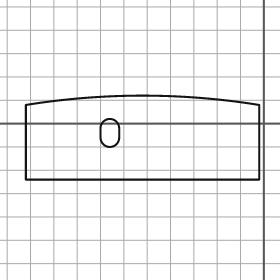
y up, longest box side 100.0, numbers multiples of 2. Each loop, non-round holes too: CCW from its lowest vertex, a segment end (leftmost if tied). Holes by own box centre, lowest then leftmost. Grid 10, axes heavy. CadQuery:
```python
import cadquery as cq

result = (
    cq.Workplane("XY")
    .moveTo(-102.0, -24.0)
    .lineTo(-2.0, -24.0)
    .lineTo(-2.0, 8.0)
    .threePointArc((-52.0, 12.0), (-102.0, 8.0))
    .close()
    .moveTo(-70.0, -6.0)
    .threePointArc((-66.0, -10.0), (-62.0, -6.0))
    .lineTo(-62.0, -2.0)
    .threePointArc((-66.0, 2.0), (-70.0, -2.0))
    .close()
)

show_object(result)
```